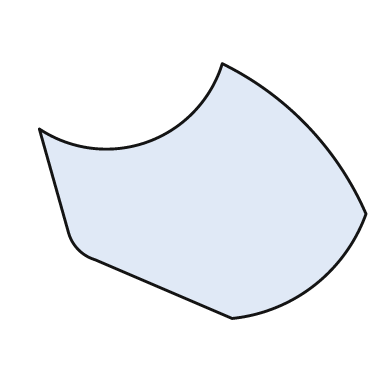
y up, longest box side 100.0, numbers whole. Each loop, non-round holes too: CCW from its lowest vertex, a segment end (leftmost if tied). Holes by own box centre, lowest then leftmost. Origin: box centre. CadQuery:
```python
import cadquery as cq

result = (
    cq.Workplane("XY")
    .moveTo(9.0, -39.0)
    .threePointArc((34.0, -29.0), (50.0, -7.0))
    .threePointArc((32.0, 20.0), (6.0, 39.0))
    .threePointArc((-17.0, 15.0), (-50.0, 19.0))
    .lineTo(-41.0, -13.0)
    .threePointArc((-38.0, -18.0), (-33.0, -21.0))
    .close()
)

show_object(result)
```